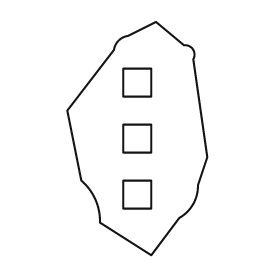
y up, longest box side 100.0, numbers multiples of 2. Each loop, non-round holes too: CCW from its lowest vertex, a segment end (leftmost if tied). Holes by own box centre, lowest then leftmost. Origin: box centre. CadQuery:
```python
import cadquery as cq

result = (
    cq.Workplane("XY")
    .moveTo(6.0, -50.0)
    .lineTo(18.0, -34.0)
    .threePointArc((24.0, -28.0), (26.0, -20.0))
    .lineTo(30.0, -8.0)
    .lineTo(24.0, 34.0)
    .threePointArc((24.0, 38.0), (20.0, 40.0))
    .lineTo(8.0, 50.0)
    .lineTo(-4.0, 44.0)
    .threePointArc((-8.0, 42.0), (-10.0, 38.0))
    .lineTo(-30.0, 12.0)
    .lineTo(-24.0, -18.0)
    .threePointArc((-18.0, -26.0), (-16.0, -36.0))
    .close()
    .moveTo(-6.0, -30.0)
    .lineTo(6.0, -30.0)
    .lineTo(6.0, -18.0)
    .lineTo(-6.0, -18.0)
    .close()
    .moveTo(-6.0, -6.0)
    .lineTo(6.0, -6.0)
    .lineTo(6.0, 6.0)
    .lineTo(-6.0, 6.0)
    .close()
    .moveTo(-6.0, 18.0)
    .lineTo(6.0, 18.0)
    .lineTo(6.0, 30.0)
    .lineTo(-6.0, 30.0)
    .close()
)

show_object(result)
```